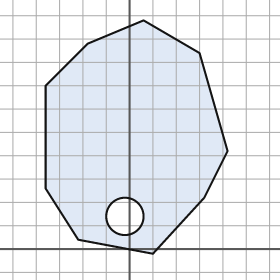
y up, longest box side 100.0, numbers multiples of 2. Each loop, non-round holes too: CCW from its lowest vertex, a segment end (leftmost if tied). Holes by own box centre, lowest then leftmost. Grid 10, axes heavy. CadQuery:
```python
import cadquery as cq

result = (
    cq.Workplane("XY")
    .moveTo(10.0, -2.0)
    .lineTo(32.0, 22.0)
    .lineTo(42.0, 42.0)
    .lineTo(30.0, 84.0)
    .lineTo(6.0, 98.0)
    .lineTo(-18.0, 88.0)
    .lineTo(-36.0, 70.0)
    .lineTo(-36.0, 26.0)
    .lineTo(-22.0, 4.0)
    .close()
    .moveTo(-2.0, 14.0)
    .circle(8.0)
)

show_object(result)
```